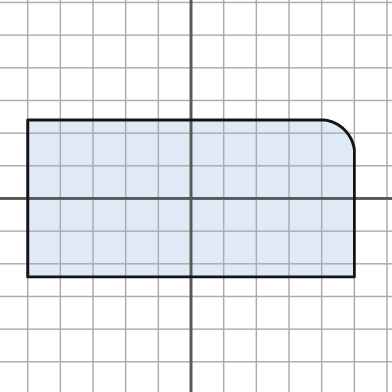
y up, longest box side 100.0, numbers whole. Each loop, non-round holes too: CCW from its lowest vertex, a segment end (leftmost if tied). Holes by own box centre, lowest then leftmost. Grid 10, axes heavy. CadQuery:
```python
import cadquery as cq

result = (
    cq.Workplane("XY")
    .moveTo(-50.0, -24.0)
    .lineTo(50.0, -24.0)
    .lineTo(50.0, 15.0)
    .threePointArc((47.0, 21.0), (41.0, 24.0))
    .lineTo(-50.0, 24.0)
    .close()
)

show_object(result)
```